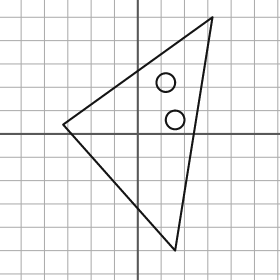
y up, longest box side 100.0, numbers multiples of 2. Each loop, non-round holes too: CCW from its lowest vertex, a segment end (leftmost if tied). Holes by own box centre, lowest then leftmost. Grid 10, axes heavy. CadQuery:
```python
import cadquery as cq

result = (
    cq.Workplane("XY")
    .moveTo(16.0, -50.0)
    .lineTo(32.0, 50.0)
    .lineTo(-32.0, 4.0)
    .close()
    .moveTo(16.0, 6.0)
    .circle(4.0)
    .moveTo(12.0, 22.0)
    .circle(4.0)
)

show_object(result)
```